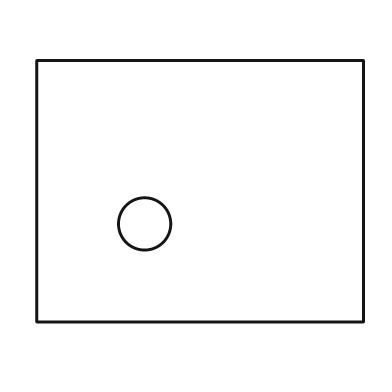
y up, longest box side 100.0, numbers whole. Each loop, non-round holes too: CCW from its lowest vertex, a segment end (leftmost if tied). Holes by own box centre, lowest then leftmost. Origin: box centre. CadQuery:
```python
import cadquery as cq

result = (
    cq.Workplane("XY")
    .moveTo(-50.0, -40.0)
    .lineTo(50.0, -40.0)
    .lineTo(50.0, 40.0)
    .lineTo(-50.0, 40.0)
    .close()
    .moveTo(-17.0, -10.0)
    .circle(8.0)
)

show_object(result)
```